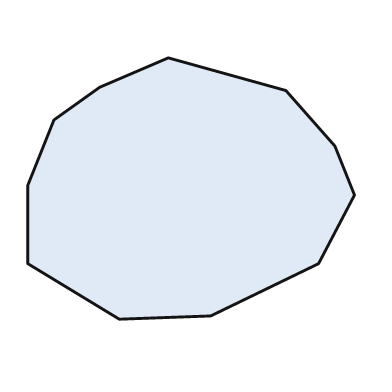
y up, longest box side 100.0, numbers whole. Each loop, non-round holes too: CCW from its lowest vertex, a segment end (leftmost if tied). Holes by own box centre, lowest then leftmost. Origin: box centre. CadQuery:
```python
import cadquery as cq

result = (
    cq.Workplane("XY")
    .moveTo(-22.0, -40.0)
    .lineTo(6.0, -39.0)
    .lineTo(39.0, -23.0)
    .lineTo(50.0, -2.0)
    .lineTo(44.0, 13.0)
    .lineTo(29.0, 30.0)
    .lineTo(-7.0, 40.0)
    .lineTo(-28.0, 31.0)
    .lineTo(-42.0, 21.0)
    .lineTo(-50.0, 1.0)
    .lineTo(-50.0, -23.0)
    .close()
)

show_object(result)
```